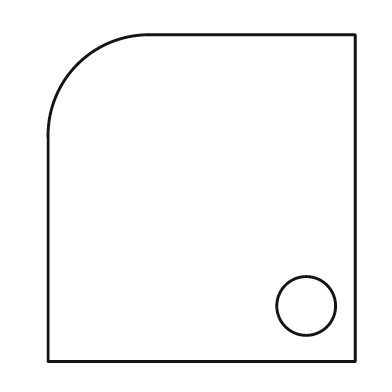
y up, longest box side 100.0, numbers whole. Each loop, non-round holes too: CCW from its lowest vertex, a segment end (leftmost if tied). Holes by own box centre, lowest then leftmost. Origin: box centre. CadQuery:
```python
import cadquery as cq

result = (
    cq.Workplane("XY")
    .moveTo(-47.0, -50.0)
    .lineTo(47.0, -50.0)
    .lineTo(47.0, 50.0)
    .lineTo(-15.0, 50.0)
    .threePointArc((-38.0, 41.0), (-47.0, 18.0))
    .close()
    .moveTo(32.0, -33.0)
    .circle(9.0)
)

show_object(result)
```